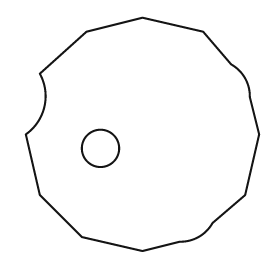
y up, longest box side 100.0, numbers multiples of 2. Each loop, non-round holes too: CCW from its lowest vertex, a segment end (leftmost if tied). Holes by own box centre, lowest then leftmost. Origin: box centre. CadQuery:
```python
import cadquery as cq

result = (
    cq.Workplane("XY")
    .moveTo(0.0, -50.0)
    .lineTo(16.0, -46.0)
    .threePointArc((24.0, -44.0), (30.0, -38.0))
    .lineTo(44.0, -26.0)
    .lineTo(50.0, 0.0)
    .lineTo(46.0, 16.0)
    .threePointArc((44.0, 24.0), (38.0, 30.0))
    .lineTo(26.0, 44.0)
    .lineTo(0.0, 50.0)
    .lineTo(-24.0, 44.0)
    .lineTo(-44.0, 26.0)
    .threePointArc((-42.0, 12.0), (-50.0, 0.0))
    .lineTo(-44.0, -26.0)
    .lineTo(-26.0, -44.0)
    .close()
    .moveTo(-18.0, -6.0)
    .circle(8.0)
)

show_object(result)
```